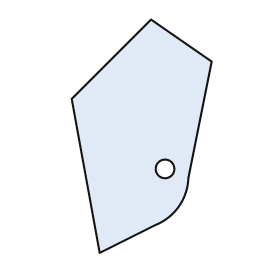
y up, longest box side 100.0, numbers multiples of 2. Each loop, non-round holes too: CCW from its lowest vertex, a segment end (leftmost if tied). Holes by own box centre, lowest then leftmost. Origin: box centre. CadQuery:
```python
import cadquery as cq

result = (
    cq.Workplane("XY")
    .moveTo(-18.0, -50.0)
    .lineTo(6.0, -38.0)
    .threePointArc((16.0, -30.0), (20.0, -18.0))
    .lineTo(30.0, 32.0)
    .lineTo(4.0, 50.0)
    .lineTo(-30.0, 16.0)
    .close()
    .moveTo(10.0, -14.0)
    .circle(4.0)
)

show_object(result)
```